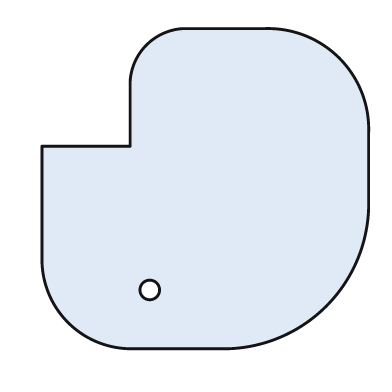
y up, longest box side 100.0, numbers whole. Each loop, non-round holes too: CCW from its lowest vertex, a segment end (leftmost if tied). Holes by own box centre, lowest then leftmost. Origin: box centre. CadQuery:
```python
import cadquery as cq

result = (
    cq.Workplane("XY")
    .moveTo(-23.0, -49.0)
    .lineTo(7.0, -49.0)
    .threePointArc((37.0, -36.0), (50.0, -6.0))
    .lineTo(50.0, 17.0)
    .threePointArc((41.0, 40.0), (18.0, 49.0))
    .lineTo(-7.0, 49.0)
    .threePointArc((-18.0, 44.0), (-23.0, 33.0))
    .lineTo(-23.0, 13.0)
    .lineTo(-50.0, 13.0)
    .lineTo(-50.0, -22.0)
    .threePointArc((-42.0, -41.0), (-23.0, -49.0))
    .close()
    .moveTo(-17.0, -31.0)
    .circle(3.0)
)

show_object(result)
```